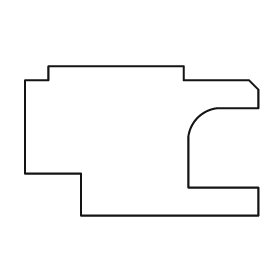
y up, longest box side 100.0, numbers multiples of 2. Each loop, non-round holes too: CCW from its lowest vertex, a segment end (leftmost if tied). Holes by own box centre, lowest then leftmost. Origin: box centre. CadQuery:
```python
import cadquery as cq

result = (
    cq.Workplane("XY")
    .moveTo(-26.0, -32.0)
    .lineTo(50.0, -32.0)
    .lineTo(50.0, -20.0)
    .lineTo(20.0, -20.0)
    .lineTo(20.0, 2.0)
    .threePointArc((24.0, 10.0), (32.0, 14.0))
    .lineTo(50.0, 14.0)
    .lineTo(50.0, 22.0)
    .lineTo(46.0, 26.0)
    .lineTo(18.0, 26.0)
    .lineTo(18.0, 32.0)
    .lineTo(-40.0, 32.0)
    .lineTo(-40.0, 26.0)
    .lineTo(-50.0, 26.0)
    .lineTo(-50.0, -14.0)
    .lineTo(-26.0, -14.0)
    .close()
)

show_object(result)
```